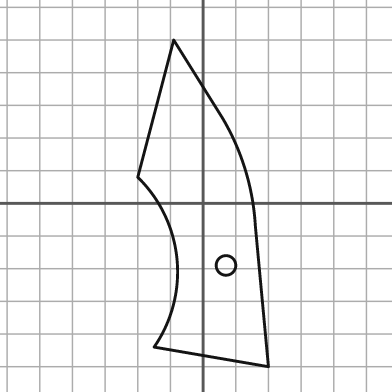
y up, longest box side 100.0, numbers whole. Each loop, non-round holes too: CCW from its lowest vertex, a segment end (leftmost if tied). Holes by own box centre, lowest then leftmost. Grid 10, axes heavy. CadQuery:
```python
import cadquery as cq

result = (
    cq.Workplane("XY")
    .moveTo(20.0, -50.0)
    .lineTo(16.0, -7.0)
    .threePointArc((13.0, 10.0), (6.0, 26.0))
    .lineTo(-9.0, 50.0)
    .lineTo(-20.0, 8.0)
    .threePointArc((-8.0, -17.0), (-15.0, -44.0))
    .close()
    .moveTo(7.0, -19.0)
    .circle(3.0)
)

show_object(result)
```